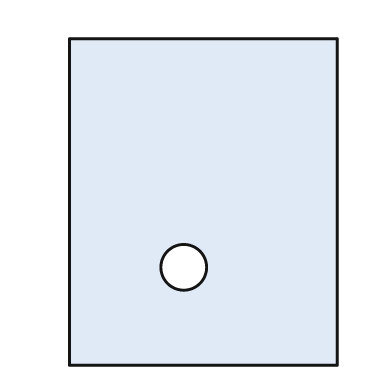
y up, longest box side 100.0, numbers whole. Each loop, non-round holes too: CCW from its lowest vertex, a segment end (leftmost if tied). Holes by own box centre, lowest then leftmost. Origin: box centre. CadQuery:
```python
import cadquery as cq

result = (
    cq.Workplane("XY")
    .moveTo(-41.0, -50.0)
    .lineTo(41.0, -50.0)
    .lineTo(41.0, 50.0)
    .lineTo(-41.0, 50.0)
    .close()
    .moveTo(-6.0, -20.0)
    .circle(7.0)
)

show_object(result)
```